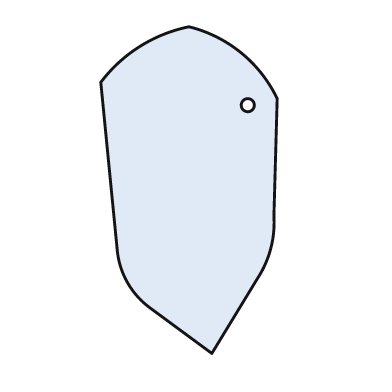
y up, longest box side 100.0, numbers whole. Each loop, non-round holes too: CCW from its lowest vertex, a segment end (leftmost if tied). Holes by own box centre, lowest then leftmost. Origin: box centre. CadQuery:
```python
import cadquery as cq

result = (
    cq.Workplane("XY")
    .moveTo(7.0, -50.0)
    .lineTo(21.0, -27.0)
    .threePointArc((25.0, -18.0), (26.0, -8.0))
    .lineTo(27.0, 28.0)
    .threePointArc((16.0, 42.0), (0.0, 50.0))
    .threePointArc((-15.0, 44.0), (-27.0, 33.0))
    .lineTo(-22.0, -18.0)
    .threePointArc((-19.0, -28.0), (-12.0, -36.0))
    .close()
    .moveTo(18.0, 26.0)
    .circle(2.0)
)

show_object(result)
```